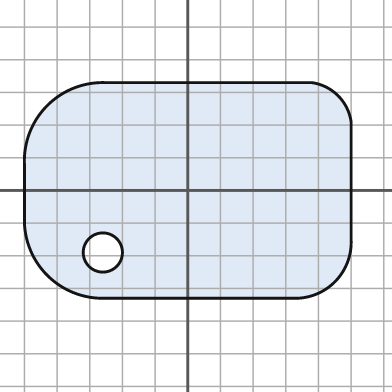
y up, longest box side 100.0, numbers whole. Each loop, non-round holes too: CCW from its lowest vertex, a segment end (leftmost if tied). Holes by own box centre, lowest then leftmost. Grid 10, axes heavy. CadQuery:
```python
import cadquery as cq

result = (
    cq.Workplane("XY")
    .moveTo(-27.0, -33.0)
    .lineTo(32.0, -33.0)
    .threePointArc((45.0, -28.0), (50.0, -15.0))
    .lineTo(50.0, 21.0)
    .threePointArc((46.0, 29.0), (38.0, 33.0))
    .lineTo(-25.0, 33.0)
    .threePointArc((-43.0, 26.0), (-50.0, 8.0))
    .lineTo(-50.0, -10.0)
    .threePointArc((-43.0, -26.0), (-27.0, -33.0))
    .close()
    .moveTo(-26.0, -19.0)
    .circle(6.0)
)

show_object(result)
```